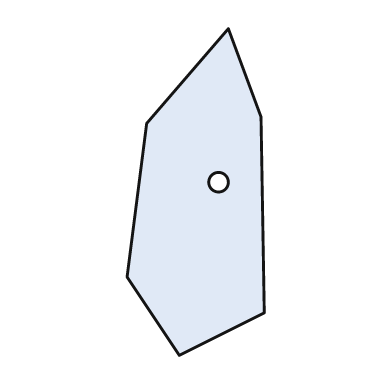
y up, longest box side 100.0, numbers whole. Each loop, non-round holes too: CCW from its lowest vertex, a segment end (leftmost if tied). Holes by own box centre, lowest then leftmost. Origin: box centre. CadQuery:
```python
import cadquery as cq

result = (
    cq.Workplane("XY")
    .moveTo(-5.0, -50.0)
    .lineTo(21.0, -37.0)
    .lineTo(20.0, 23.0)
    .lineTo(10.0, 50.0)
    .lineTo(-15.0, 21.0)
    .lineTo(-21.0, -26.0)
    .close()
    .moveTo(7.0, 3.0)
    .circle(3.0)
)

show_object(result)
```